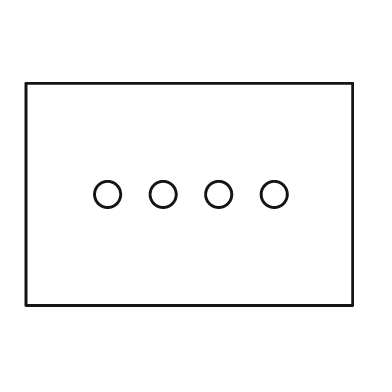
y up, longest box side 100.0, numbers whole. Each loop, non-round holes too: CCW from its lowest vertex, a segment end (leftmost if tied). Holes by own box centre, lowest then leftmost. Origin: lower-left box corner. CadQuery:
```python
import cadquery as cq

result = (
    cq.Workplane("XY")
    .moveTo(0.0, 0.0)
    .lineTo(100.0, 0.0)
    .lineTo(100.0, 68.0)
    .lineTo(0.0, 68.0)
    .close()
    .moveTo(25.0, 34.0)
    .circle(4.0)
    .moveTo(42.0, 34.0)
    .circle(4.0)
    .moveTo(59.0, 34.0)
    .circle(4.0)
    .moveTo(76.0, 34.0)
    .circle(4.0)
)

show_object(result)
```